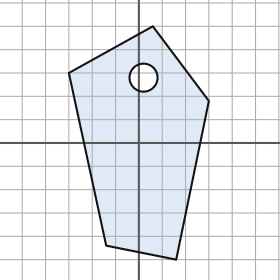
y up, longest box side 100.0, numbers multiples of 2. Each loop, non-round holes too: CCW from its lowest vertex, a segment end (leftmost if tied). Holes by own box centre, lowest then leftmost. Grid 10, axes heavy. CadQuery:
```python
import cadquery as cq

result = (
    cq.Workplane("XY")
    .moveTo(16.0, -50.0)
    .lineTo(30.0, 18.0)
    .lineTo(6.0, 50.0)
    .lineTo(-30.0, 30.0)
    .lineTo(-14.0, -44.0)
    .close()
    .moveTo(2.0, 28.0)
    .circle(6.0)
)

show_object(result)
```